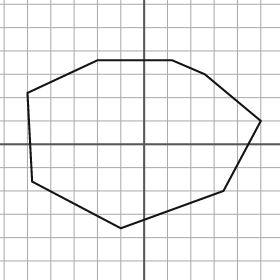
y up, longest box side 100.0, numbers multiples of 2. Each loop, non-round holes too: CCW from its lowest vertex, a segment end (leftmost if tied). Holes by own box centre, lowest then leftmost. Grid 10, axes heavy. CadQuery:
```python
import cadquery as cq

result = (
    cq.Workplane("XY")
    .moveTo(-10.0, -36.0)
    .lineTo(34.0, -20.0)
    .lineTo(50.0, 10.0)
    .lineTo(26.0, 30.0)
    .lineTo(12.0, 36.0)
    .lineTo(-20.0, 36.0)
    .lineTo(-50.0, 22.0)
    .lineTo(-48.0, -16.0)
    .close()
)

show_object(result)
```